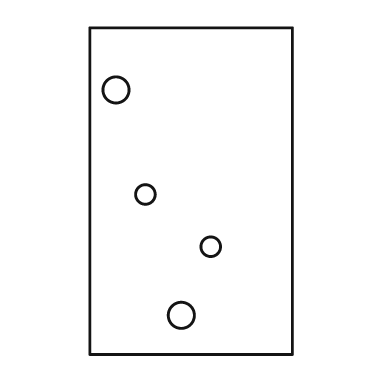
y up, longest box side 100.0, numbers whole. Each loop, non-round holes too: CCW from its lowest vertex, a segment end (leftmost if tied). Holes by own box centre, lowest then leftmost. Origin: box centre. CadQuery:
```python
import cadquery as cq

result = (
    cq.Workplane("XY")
    .moveTo(-31.0, -50.0)
    .lineTo(31.0, -50.0)
    .lineTo(31.0, 50.0)
    .lineTo(-31.0, 50.0)
    .close()
    .moveTo(-3.0, -38.0)
    .circle(4.0)
    .moveTo(6.0, -17.0)
    .circle(3.0)
    .moveTo(-14.0, -1.0)
    .circle(3.0)
    .moveTo(-23.0, 31.0)
    .circle(4.0)
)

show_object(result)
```